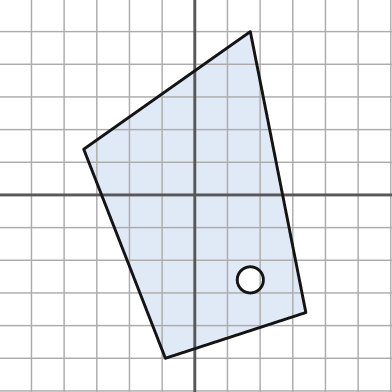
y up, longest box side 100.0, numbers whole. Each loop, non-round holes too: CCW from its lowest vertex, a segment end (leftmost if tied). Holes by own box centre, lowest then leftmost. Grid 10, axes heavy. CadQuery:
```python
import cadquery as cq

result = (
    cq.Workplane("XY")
    .moveTo(-9.0, -50.0)
    .lineTo(34.0, -36.0)
    .lineTo(17.0, 50.0)
    .lineTo(-34.0, 14.0)
    .close()
    .moveTo(17.0, -26.0)
    .circle(4.0)
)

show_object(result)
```